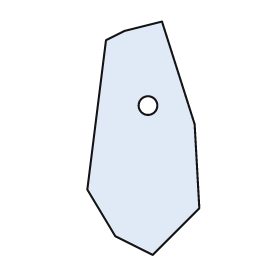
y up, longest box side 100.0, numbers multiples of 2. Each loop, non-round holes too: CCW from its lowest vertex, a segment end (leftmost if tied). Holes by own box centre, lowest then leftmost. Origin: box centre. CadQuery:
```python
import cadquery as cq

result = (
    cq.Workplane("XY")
    .moveTo(4.0, -50.0)
    .lineTo(24.0, -30.0)
    .lineTo(22.0, 6.0)
    .lineTo(8.0, 50.0)
    .lineTo(-8.0, 46.0)
    .lineTo(-16.0, 42.0)
    .lineTo(-24.0, -22.0)
    .lineTo(-12.0, -42.0)
    .close()
    .moveTo(2.0, 14.0)
    .circle(4.0)
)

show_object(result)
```